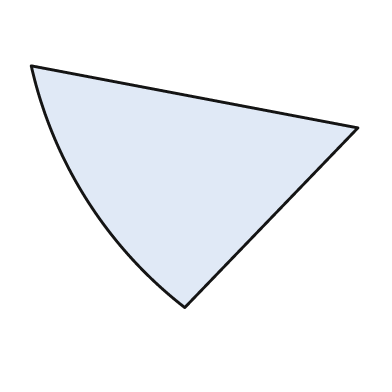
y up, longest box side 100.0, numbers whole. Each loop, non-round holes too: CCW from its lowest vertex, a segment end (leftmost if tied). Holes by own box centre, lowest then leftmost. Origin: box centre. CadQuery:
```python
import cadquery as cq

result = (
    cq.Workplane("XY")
    .moveTo(-3.0, -37.0)
    .lineTo(50.0, 18.0)
    .lineTo(-50.0, 37.0)
    .threePointArc((-33.0, -4.0), (-3.0, -37.0))
    .close()
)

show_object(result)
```